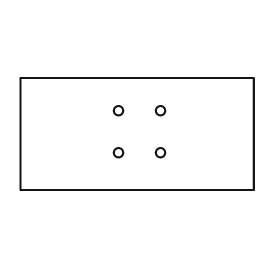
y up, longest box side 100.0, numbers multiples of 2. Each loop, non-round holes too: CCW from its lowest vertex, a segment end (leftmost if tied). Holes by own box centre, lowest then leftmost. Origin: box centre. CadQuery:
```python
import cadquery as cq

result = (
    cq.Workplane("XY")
    .moveTo(-50.0, -24.0)
    .lineTo(50.0, -24.0)
    .lineTo(50.0, 24.0)
    .lineTo(-50.0, 24.0)
    .close()
    .moveTo(-8.0, -8.0)
    .circle(2.0)
    .moveTo(10.0, -8.0)
    .circle(2.0)
    .moveTo(-8.0, 10.0)
    .circle(2.0)
    .moveTo(10.0, 10.0)
    .circle(2.0)
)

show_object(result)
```